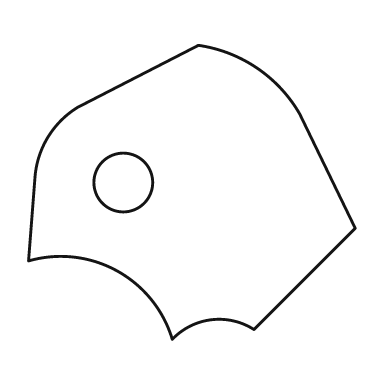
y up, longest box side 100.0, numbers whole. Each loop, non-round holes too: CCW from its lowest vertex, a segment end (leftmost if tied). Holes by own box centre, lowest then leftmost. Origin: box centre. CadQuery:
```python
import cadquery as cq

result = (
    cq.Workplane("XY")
    .moveTo(-6.0, -45.0)
    .threePointArc((6.0, -39.0), (19.0, -42.0))
    .lineTo(50.0, -11.0)
    .lineTo(33.0, 24.0)
    .threePointArc((20.0, 38.0), (2.0, 45.0))
    .lineTo(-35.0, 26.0)
    .threePointArc((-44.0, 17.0), (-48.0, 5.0))
    .lineTo(-50.0, -21.0)
    .threePointArc((-23.0, -24.0), (-6.0, -45.0))
    .close()
    .moveTo(-21.0, 3.0)
    .circle(9.0)
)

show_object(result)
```